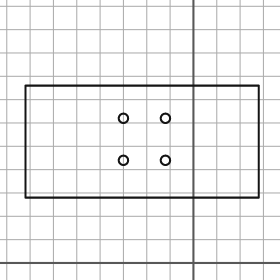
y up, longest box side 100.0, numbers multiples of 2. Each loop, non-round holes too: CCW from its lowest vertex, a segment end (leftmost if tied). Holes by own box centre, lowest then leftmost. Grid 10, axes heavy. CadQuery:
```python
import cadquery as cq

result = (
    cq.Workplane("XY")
    .moveTo(-72.0, 28.0)
    .lineTo(28.0, 28.0)
    .lineTo(28.0, 76.0)
    .lineTo(-72.0, 76.0)
    .close()
    .moveTo(-30.0, 44.0)
    .circle(2.0)
    .moveTo(-12.0, 44.0)
    .circle(2.0)
    .moveTo(-30.0, 62.0)
    .circle(2.0)
    .moveTo(-12.0, 62.0)
    .circle(2.0)
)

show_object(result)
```